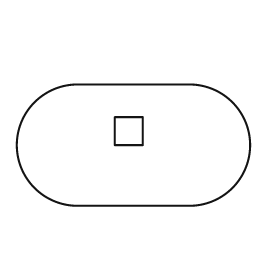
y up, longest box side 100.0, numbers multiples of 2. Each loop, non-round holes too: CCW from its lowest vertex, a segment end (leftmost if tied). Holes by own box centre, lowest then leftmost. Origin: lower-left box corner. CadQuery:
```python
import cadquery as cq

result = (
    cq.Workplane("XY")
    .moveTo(26.0, 0.0)
    .lineTo(74.0, 0.0)
    .threePointArc((100.0, 26.0), (74.0, 52.0))
    .lineTo(26.0, 52.0)
    .threePointArc((0.0, 26.0), (26.0, 0.0))
    .close()
    .moveTo(42.0, 26.0)
    .lineTo(54.0, 26.0)
    .lineTo(54.0, 38.0)
    .lineTo(42.0, 38.0)
    .close()
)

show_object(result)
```